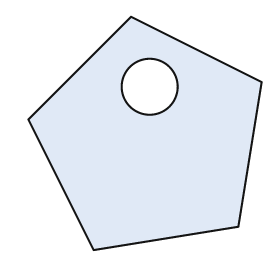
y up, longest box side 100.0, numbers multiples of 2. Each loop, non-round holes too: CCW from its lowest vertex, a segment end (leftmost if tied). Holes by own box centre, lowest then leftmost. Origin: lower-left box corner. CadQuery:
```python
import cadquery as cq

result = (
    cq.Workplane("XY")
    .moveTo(28.0, 0.0)
    .lineTo(90.0, 10.0)
    .lineTo(100.0, 72.0)
    .lineTo(44.0, 100.0)
    .lineTo(0.0, 56.0)
    .close()
    .moveTo(52.0, 70.0)
    .circle(12.0)
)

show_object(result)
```